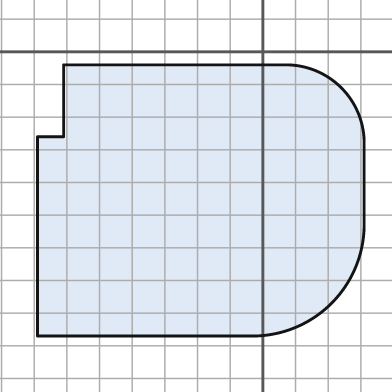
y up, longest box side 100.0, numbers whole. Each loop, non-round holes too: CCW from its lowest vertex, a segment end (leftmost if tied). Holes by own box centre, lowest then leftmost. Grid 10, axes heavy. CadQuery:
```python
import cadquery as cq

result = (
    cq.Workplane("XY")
    .moveTo(-69.0, -87.0)
    .lineTo(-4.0, -87.0)
    .threePointArc((21.0, -77.0), (31.0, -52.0))
    .lineTo(31.0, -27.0)
    .threePointArc((24.0, -11.0), (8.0, -4.0))
    .lineTo(-61.0, -4.0)
    .lineTo(-61.0, -26.0)
    .lineTo(-69.0, -26.0)
    .close()
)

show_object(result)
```